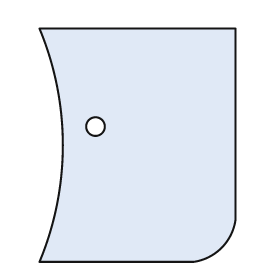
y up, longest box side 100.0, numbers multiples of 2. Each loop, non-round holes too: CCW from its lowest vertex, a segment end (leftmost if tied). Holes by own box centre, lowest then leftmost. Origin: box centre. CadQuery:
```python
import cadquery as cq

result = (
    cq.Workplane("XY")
    .moveTo(-42.0, -50.0)
    .lineTo(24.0, -50.0)
    .threePointArc((36.0, -44.0), (42.0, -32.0))
    .lineTo(42.0, 50.0)
    .lineTo(-42.0, 50.0)
    .threePointArc((-32.0, 0.0), (-42.0, -50.0))
    .close()
    .moveTo(-18.0, 8.0)
    .circle(4.0)
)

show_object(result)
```